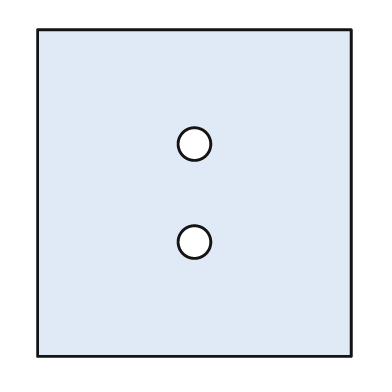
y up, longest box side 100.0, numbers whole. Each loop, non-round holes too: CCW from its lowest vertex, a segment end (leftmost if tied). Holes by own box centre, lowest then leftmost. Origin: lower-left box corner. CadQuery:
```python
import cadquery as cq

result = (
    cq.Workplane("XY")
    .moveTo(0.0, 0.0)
    .lineTo(96.0, 0.0)
    .lineTo(96.0, 100.0)
    .lineTo(0.0, 100.0)
    .close()
    .moveTo(48.0, 35.0)
    .circle(5.0)
    .moveTo(48.0, 65.0)
    .circle(5.0)
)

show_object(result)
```